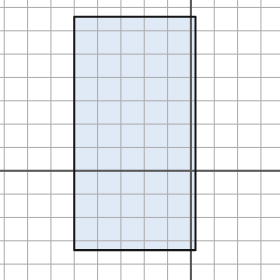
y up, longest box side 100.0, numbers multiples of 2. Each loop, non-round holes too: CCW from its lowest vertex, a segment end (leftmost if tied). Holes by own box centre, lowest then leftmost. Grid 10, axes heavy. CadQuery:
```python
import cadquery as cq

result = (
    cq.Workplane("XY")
    .moveTo(-50.0, -34.0)
    .lineTo(2.0, -34.0)
    .lineTo(2.0, 66.0)
    .lineTo(-50.0, 66.0)
    .close()
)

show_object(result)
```